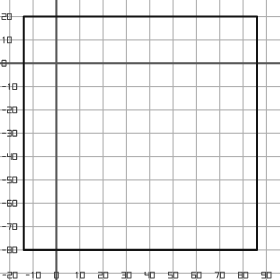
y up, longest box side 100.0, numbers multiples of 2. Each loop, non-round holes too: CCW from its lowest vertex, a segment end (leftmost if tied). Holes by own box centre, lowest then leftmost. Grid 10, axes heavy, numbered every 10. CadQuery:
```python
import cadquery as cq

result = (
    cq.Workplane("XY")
    .moveTo(-14.0, -80.0)
    .lineTo(86.0, -80.0)
    .lineTo(86.0, 20.0)
    .lineTo(-14.0, 20.0)
    .close()
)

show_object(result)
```